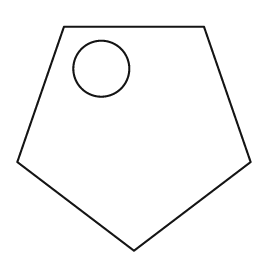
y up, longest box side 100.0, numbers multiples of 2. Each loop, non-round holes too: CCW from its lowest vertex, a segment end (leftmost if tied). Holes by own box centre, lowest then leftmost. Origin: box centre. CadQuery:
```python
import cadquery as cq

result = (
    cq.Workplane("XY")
    .moveTo(0.0, -48.0)
    .lineTo(50.0, -10.0)
    .lineTo(30.0, 48.0)
    .lineTo(-30.0, 48.0)
    .lineTo(-50.0, -10.0)
    .close()
    .moveTo(-14.0, 30.0)
    .circle(12.0)
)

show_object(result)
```